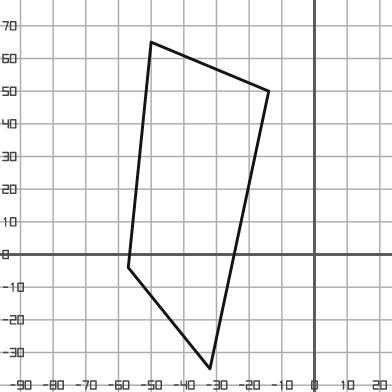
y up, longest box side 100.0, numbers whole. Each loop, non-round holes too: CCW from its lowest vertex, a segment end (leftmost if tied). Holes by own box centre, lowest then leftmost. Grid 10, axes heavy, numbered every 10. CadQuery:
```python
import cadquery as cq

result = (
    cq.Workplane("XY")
    .moveTo(-32.0, -35.0)
    .lineTo(-14.0, 50.0)
    .lineTo(-50.0, 65.0)
    .lineTo(-57.0, -4.0)
    .close()
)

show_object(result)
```